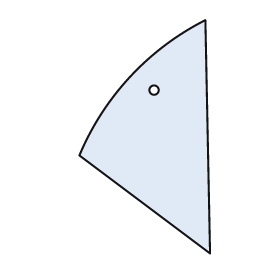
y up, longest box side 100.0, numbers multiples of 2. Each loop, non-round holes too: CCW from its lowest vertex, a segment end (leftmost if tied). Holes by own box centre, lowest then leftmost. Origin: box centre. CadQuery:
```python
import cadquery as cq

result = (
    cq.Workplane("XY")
    .moveTo(28.0, -50.0)
    .lineTo(26.0, 50.0)
    .threePointArc((-6.0, 26.0), (-28.0, -8.0))
    .close()
    .moveTo(4.0, 20.0)
    .circle(2.0)
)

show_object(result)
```